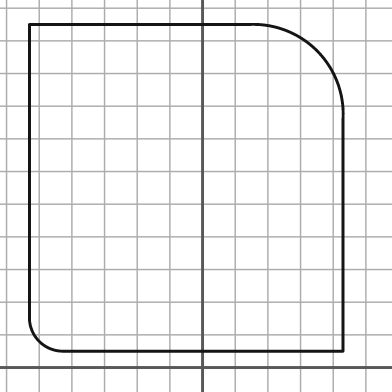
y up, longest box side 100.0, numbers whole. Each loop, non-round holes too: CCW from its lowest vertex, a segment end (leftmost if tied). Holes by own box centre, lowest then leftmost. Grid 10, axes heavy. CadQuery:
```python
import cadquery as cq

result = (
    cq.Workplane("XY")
    .moveTo(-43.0, 5.0)
    .lineTo(43.0, 5.0)
    .lineTo(43.0, 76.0)
    .threePointArc((35.0, 97.0), (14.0, 105.0))
    .lineTo(-53.0, 105.0)
    .lineTo(-53.0, 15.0)
    .threePointArc((-50.0, 8.0), (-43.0, 5.0))
    .close()
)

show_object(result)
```